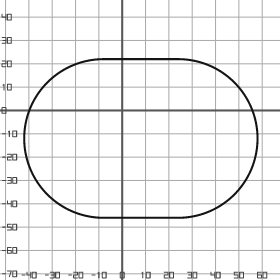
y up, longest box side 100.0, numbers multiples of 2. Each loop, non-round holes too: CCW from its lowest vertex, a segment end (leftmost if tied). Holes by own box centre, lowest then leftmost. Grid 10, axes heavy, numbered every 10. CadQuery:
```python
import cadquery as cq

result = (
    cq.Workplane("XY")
    .moveTo(-8.0, -46.0)
    .lineTo(24.0, -46.0)
    .threePointArc((58.0, -12.0), (24.0, 22.0))
    .lineTo(-8.0, 22.0)
    .threePointArc((-42.0, -12.0), (-8.0, -46.0))
    .close()
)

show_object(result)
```